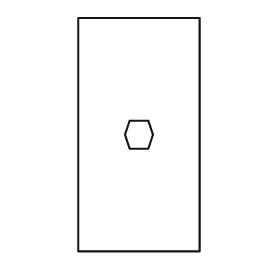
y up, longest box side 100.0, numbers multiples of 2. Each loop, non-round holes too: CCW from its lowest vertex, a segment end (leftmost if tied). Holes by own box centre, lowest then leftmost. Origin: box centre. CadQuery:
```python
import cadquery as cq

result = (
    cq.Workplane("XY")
    .moveTo(-26.0, -50.0)
    .lineTo(26.0, -50.0)
    .lineTo(26.0, 50.0)
    .lineTo(-26.0, 50.0)
    .close()
    .moveTo(-4.0, -6.0)
    .lineTo(4.0, -6.0)
    .lineTo(6.0, 0.0)
    .lineTo(4.0, 6.0)
    .lineTo(-4.0, 6.0)
    .lineTo(-6.0, 0.0)
    .close()
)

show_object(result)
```